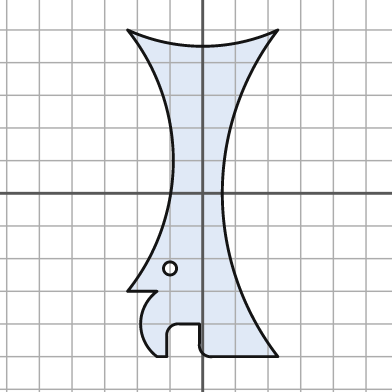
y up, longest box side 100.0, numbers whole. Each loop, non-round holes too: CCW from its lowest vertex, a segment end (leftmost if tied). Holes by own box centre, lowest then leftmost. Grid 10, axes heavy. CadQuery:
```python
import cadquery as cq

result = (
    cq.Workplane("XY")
    .moveTo(-14.0, -50.0)
    .lineTo(-11.0, -50.0)
    .lineTo(-11.0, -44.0)
    .threePointArc((-10.0, -41.0), (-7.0, -40.0))
    .lineTo(-1.0, -40.0)
    .lineTo(-1.0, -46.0)
    .threePointArc((0.0, -49.0), (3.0, -50.0))
    .lineTo(23.0, -50.0)
    .threePointArc((6.0, 0.0), (23.0, 50.0))
    .threePointArc((0.0, 45.0), (-23.0, 50.0))
    .threePointArc((-9.0, 10.0), (-23.0, -30.0))
    .lineTo(-14.0, -30.0)
    .threePointArc((-19.0, -40.0), (-14.0, -50.0))
    .close()
    .moveTo(-10.0, -23.0)
    .circle(2.0)
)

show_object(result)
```